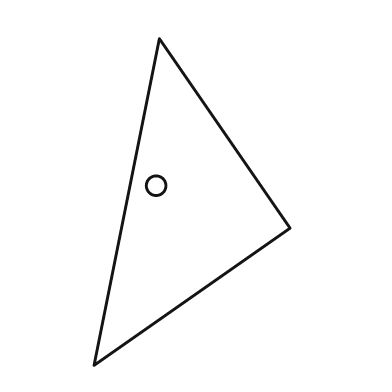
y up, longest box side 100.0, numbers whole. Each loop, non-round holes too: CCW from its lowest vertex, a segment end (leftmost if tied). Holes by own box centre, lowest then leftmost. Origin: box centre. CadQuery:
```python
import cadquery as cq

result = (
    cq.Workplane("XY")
    .moveTo(-30.0, -50.0)
    .lineTo(30.0, -8.0)
    .lineTo(-10.0, 50.0)
    .close()
    .moveTo(-11.0, 5.0)
    .circle(3.0)
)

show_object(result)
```